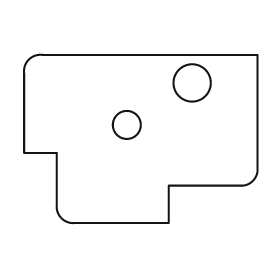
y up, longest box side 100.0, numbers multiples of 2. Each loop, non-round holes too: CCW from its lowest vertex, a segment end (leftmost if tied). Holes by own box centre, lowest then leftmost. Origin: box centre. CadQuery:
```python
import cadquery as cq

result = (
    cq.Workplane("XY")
    .moveTo(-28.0, -36.0)
    .lineTo(12.0, -36.0)
    .lineTo(12.0, -20.0)
    .lineTo(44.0, -20.0)
    .threePointArc((48.0, -18.0), (50.0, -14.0))
    .lineTo(50.0, 36.0)
    .lineTo(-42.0, 36.0)
    .threePointArc((-48.0, 34.0), (-50.0, 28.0))
    .lineTo(-50.0, -6.0)
    .lineTo(-36.0, -6.0)
    .lineTo(-36.0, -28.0)
    .threePointArc((-34.0, -34.0), (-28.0, -36.0))
    .close()
    .moveTo(-6.0, 6.0)
    .circle(6.0)
    .moveTo(22.0, 24.0)
    .circle(8.0)
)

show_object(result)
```